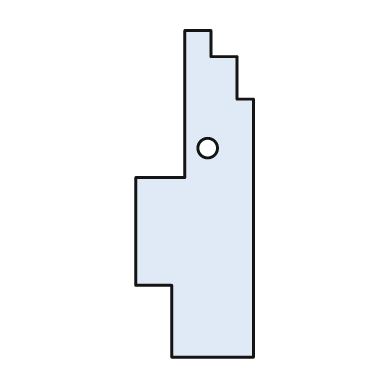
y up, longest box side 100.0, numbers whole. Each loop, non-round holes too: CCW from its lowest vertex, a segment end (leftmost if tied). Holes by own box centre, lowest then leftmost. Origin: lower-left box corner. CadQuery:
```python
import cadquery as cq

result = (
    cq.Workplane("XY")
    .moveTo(11.0, 0.0)
    .lineTo(36.0, 0.0)
    .lineTo(36.0, 79.0)
    .lineTo(31.0, 79.0)
    .lineTo(31.0, 92.0)
    .lineTo(23.0, 92.0)
    .lineTo(23.0, 100.0)
    .lineTo(15.0, 100.0)
    .lineTo(15.0, 55.0)
    .lineTo(0.0, 55.0)
    .lineTo(0.0, 22.0)
    .lineTo(11.0, 22.0)
    .close()
    .moveTo(22.0, 64.0)
    .circle(3.0)
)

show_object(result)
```